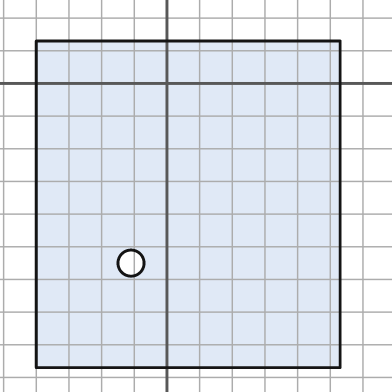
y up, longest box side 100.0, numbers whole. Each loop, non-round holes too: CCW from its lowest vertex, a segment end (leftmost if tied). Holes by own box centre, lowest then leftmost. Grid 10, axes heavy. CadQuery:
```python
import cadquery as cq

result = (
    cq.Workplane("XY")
    .moveTo(-40.0, -87.0)
    .lineTo(53.0, -87.0)
    .lineTo(53.0, 13.0)
    .lineTo(-40.0, 13.0)
    .close()
    .moveTo(-11.0, -55.0)
    .circle(4.0)
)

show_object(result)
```